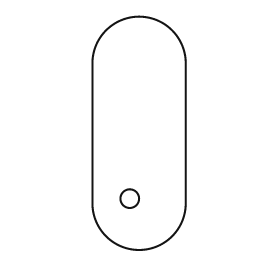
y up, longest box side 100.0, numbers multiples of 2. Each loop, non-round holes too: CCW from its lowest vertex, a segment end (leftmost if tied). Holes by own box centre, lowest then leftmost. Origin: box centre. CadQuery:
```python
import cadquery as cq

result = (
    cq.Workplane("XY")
    .moveTo(-20.0, -30.0)
    .threePointArc((0.0, -50.0), (20.0, -30.0))
    .lineTo(20.0, 30.0)
    .threePointArc((0.0, 50.0), (-20.0, 30.0))
    .close()
    .moveTo(-4.0, -28.0)
    .circle(4.0)
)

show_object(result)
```